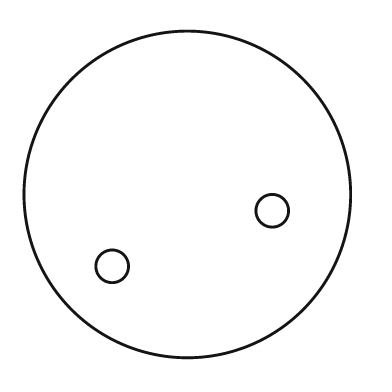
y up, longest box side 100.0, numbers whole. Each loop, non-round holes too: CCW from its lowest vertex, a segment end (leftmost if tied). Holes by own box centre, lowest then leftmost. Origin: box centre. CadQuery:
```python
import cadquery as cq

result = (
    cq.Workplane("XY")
    .moveTo(0.0, 0.0)
    .circle(50.0)
    .moveTo(-23.0, -22.0)
    .circle(5.0)
    .moveTo(26.0, -5.0)
    .circle(5.0)
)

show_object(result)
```